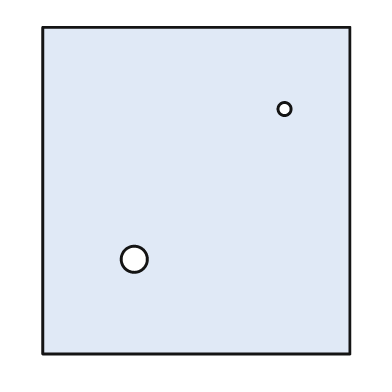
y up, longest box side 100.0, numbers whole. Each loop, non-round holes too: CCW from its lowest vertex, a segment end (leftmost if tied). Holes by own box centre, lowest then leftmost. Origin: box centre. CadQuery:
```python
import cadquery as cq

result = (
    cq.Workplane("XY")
    .moveTo(-47.0, -50.0)
    .lineTo(47.0, -50.0)
    .lineTo(47.0, 50.0)
    .lineTo(-47.0, 50.0)
    .close()
    .moveTo(-19.0, -21.0)
    .circle(4.0)
    .moveTo(27.0, 25.0)
    .circle(2.0)
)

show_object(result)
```